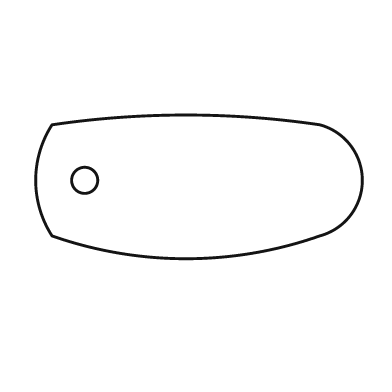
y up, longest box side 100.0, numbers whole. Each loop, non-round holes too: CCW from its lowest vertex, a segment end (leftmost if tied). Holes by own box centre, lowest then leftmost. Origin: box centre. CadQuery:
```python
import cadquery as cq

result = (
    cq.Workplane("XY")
    .moveTo(-45.0, -15.0)
    .threePointArc((-4.0, -22.0), (37.0, -15.0))
    .threePointArc((50.0, 2.0), (37.0, 19.0))
    .threePointArc((-4.0, 22.0), (-45.0, 19.0))
    .threePointArc((-50.0, 2.0), (-45.0, -15.0))
    .close()
    .moveTo(-35.0, 2.0)
    .circle(4.0)
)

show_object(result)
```